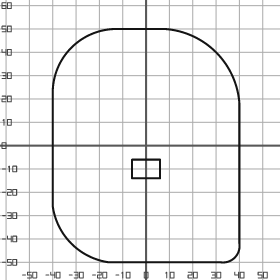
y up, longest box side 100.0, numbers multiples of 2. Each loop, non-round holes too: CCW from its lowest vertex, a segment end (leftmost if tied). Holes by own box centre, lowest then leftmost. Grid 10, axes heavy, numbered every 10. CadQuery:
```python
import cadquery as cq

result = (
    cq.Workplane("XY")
    .moveTo(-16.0, -50.0)
    .lineTo(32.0, -50.0)
    .threePointArc((38.0, -48.0), (40.0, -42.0))
    .lineTo(40.0, 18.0)
    .threePointArc((30.0, 40.0), (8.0, 50.0))
    .lineTo(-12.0, 50.0)
    .threePointArc((-32.0, 42.0), (-40.0, 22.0))
    .lineTo(-40.0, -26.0)
    .threePointArc((-32.0, -42.0), (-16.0, -50.0))
    .close()
    .moveTo(-6.0, -14.0)
    .lineTo(6.0, -14.0)
    .lineTo(6.0, -6.0)
    .lineTo(-6.0, -6.0)
    .close()
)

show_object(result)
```